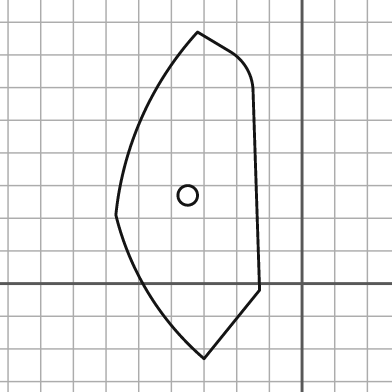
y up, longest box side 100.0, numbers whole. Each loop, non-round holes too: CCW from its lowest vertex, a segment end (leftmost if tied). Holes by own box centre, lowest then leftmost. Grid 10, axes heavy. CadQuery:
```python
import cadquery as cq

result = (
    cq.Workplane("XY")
    .moveTo(-30.0, -23.0)
    .lineTo(-13.0, -2.0)
    .lineTo(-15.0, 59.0)
    .threePointArc((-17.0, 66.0), (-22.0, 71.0))
    .lineTo(-32.0, 77.0)
    .threePointArc((-49.0, 51.0), (-57.0, 21.0))
    .threePointArc((-47.0, -3.0), (-30.0, -23.0))
    .close()
    .moveTo(-35.0, 27.0)
    .circle(3.0)
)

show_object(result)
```